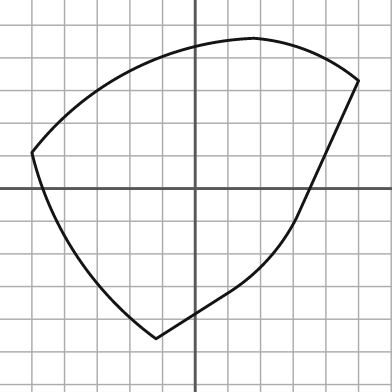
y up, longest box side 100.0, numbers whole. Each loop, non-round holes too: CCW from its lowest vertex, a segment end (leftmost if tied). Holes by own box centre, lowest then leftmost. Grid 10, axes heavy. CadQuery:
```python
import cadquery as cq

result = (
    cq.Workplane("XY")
    .moveTo(-12.0, -46.0)
    .lineTo(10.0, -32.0)
    .threePointArc((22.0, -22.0), (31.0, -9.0))
    .lineTo(50.0, 33.0)
    .threePointArc((35.0, 42.0), (18.0, 46.0))
    .threePointArc((-20.0, 36.0), (-50.0, 11.0))
    .threePointArc((-36.0, -21.0), (-12.0, -46.0))
    .close()
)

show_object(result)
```